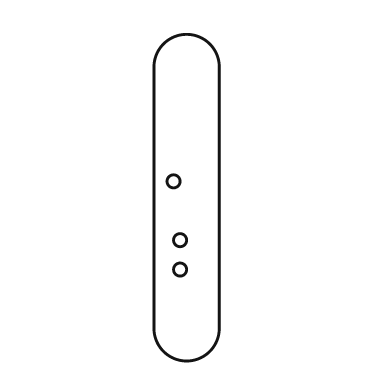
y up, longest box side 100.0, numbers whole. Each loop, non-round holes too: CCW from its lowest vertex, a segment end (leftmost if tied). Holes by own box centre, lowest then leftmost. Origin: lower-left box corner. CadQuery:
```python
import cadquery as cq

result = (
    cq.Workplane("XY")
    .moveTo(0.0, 10.0)
    .threePointArc((10.0, 0.0), (20.0, 10.0))
    .lineTo(20.0, 90.0)
    .threePointArc((10.0, 100.0), (0.0, 90.0))
    .close()
    .moveTo(8.0, 28.0)
    .circle(2.0)
    .moveTo(8.0, 37.0)
    .circle(2.0)
    .moveTo(6.0, 55.0)
    .circle(2.0)
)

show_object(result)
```